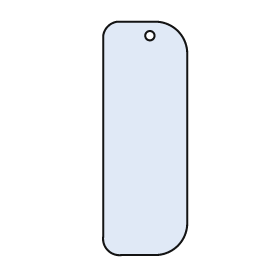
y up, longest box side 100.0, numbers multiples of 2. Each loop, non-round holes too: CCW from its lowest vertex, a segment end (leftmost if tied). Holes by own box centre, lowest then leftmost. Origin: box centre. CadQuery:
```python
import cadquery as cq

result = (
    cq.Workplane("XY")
    .moveTo(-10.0, -50.0)
    .lineTo(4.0, -50.0)
    .threePointArc((14.0, -46.0), (18.0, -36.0))
    .lineTo(18.0, 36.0)
    .threePointArc((14.0, 46.0), (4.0, 50.0))
    .lineTo(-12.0, 50.0)
    .threePointArc((-16.0, 48.0), (-18.0, 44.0))
    .lineTo(-18.0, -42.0)
    .threePointArc((-16.0, -48.0), (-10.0, -50.0))
    .close()
    .moveTo(2.0, 44.0)
    .circle(2.0)
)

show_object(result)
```